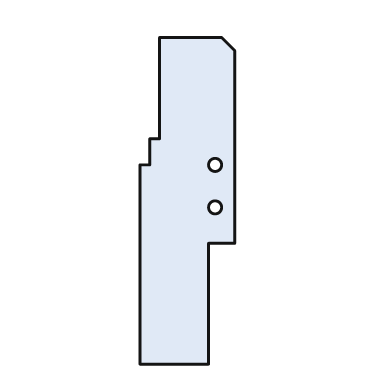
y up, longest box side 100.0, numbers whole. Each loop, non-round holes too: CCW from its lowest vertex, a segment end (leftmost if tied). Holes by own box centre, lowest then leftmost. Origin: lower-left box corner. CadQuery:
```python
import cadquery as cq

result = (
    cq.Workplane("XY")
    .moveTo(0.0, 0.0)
    .lineTo(21.0, 0.0)
    .lineTo(21.0, 37.0)
    .lineTo(29.0, 37.0)
    .lineTo(29.0, 96.0)
    .lineTo(25.0, 100.0)
    .lineTo(6.0, 100.0)
    .lineTo(6.0, 69.0)
    .lineTo(3.0, 69.0)
    .lineTo(3.0, 61.0)
    .lineTo(0.0, 61.0)
    .close()
    .moveTo(23.0, 48.0)
    .circle(2.0)
    .moveTo(23.0, 61.0)
    .circle(2.0)
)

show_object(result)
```